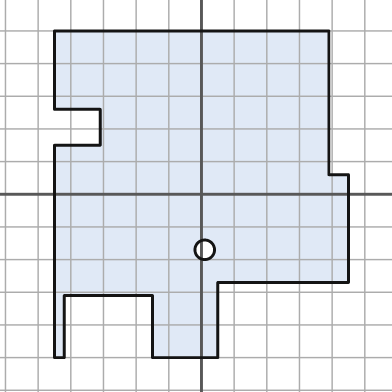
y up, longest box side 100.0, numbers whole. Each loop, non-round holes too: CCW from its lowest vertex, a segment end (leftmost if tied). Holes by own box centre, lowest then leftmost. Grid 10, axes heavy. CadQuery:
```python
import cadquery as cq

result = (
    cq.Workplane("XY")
    .moveTo(-45.0, -50.0)
    .lineTo(-42.0, -50.0)
    .lineTo(-42.0, -31.0)
    .lineTo(-15.0, -31.0)
    .lineTo(-15.0, -50.0)
    .lineTo(5.0, -50.0)
    .lineTo(5.0, -27.0)
    .lineTo(45.0, -27.0)
    .lineTo(45.0, 6.0)
    .lineTo(39.0, 6.0)
    .lineTo(39.0, 50.0)
    .lineTo(-45.0, 50.0)
    .lineTo(-45.0, 26.0)
    .lineTo(-31.0, 26.0)
    .lineTo(-31.0, 15.0)
    .lineTo(-45.0, 15.0)
    .close()
    .moveTo(1.0, -17.0)
    .circle(3.0)
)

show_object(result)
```